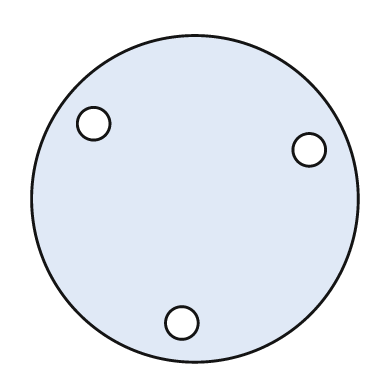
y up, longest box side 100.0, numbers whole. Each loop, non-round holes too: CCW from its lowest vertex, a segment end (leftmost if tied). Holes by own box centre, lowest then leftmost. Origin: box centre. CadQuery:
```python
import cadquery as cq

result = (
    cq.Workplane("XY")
    .moveTo(0.0, 0.0)
    .circle(50.0)
    .moveTo(-4.0, -38.0)
    .circle(5.0)
    .moveTo(35.0, 15.0)
    .circle(5.0)
    .moveTo(-31.0, 23.0)
    .circle(5.0)
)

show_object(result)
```